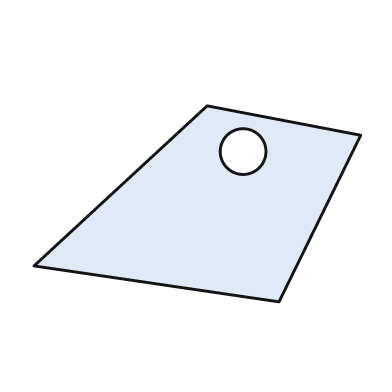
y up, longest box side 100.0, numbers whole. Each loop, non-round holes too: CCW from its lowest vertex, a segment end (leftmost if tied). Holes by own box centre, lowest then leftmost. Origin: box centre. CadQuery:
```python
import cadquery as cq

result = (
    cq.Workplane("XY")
    .moveTo(25.0, -30.0)
    .lineTo(50.0, 21.0)
    .lineTo(3.0, 30.0)
    .lineTo(-50.0, -19.0)
    .close()
    .moveTo(14.0, 16.0)
    .circle(7.0)
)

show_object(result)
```